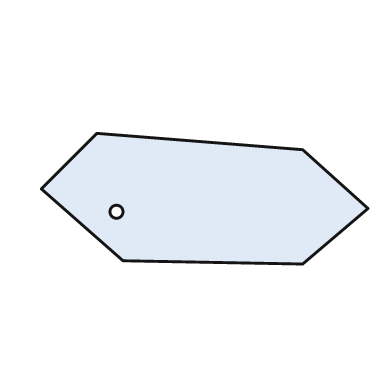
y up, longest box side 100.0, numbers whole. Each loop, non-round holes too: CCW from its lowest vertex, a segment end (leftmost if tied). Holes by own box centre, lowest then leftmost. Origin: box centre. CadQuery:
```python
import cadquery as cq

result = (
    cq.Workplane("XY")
    .moveTo(30.0, -20.0)
    .lineTo(50.0, -3.0)
    .lineTo(30.0, 15.0)
    .lineTo(-33.0, 20.0)
    .lineTo(-50.0, 3.0)
    .lineTo(-25.0, -19.0)
    .close()
    .moveTo(-27.0, -4.0)
    .circle(2.0)
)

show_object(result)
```